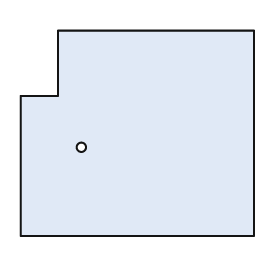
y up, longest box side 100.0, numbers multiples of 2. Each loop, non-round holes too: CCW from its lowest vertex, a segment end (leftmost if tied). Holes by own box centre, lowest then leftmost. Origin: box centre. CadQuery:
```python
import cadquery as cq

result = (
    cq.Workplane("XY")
    .moveTo(-50.0, -44.0)
    .lineTo(50.0, -44.0)
    .lineTo(50.0, 44.0)
    .lineTo(-34.0, 44.0)
    .lineTo(-34.0, 16.0)
    .lineTo(-50.0, 16.0)
    .close()
    .moveTo(-24.0, -6.0)
    .circle(2.0)
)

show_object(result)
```